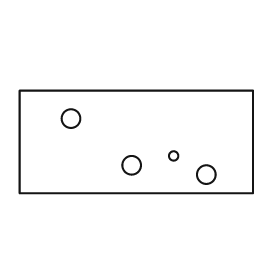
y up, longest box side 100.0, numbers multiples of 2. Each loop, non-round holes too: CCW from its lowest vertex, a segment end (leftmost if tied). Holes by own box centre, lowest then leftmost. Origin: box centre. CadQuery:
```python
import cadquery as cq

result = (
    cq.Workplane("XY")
    .moveTo(-50.0, -22.0)
    .lineTo(50.0, -22.0)
    .lineTo(50.0, 22.0)
    .lineTo(-50.0, 22.0)
    .close()
    .moveTo(30.0, -14.0)
    .circle(4.0)
    .moveTo(-2.0, -10.0)
    .circle(4.0)
    .moveTo(16.0, -6.0)
    .circle(2.0)
    .moveTo(-28.0, 10.0)
    .circle(4.0)
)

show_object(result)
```